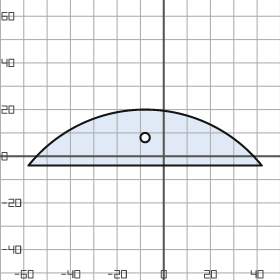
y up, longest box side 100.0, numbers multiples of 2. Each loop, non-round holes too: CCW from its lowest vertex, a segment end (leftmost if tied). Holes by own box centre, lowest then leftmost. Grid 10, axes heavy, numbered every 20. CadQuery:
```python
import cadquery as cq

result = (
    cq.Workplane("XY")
    .moveTo(-58.0, -4.0)
    .lineTo(42.0, -4.0)
    .threePointArc((-8.0, 20.0), (-58.0, -4.0))
    .close()
    .moveTo(-8.0, 8.0)
    .circle(2.0)
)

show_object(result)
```